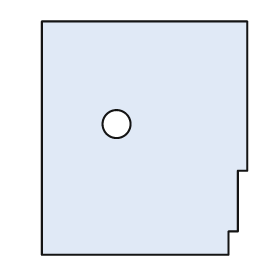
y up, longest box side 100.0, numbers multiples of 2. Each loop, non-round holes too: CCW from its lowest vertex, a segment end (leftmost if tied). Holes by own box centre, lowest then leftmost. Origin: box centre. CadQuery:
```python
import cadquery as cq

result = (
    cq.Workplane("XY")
    .moveTo(-44.0, -50.0)
    .lineTo(36.0, -50.0)
    .lineTo(36.0, -40.0)
    .lineTo(40.0, -40.0)
    .lineTo(40.0, -14.0)
    .lineTo(44.0, -14.0)
    .lineTo(44.0, 50.0)
    .lineTo(-44.0, 50.0)
    .close()
    .moveTo(-12.0, 6.0)
    .circle(6.0)
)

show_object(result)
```